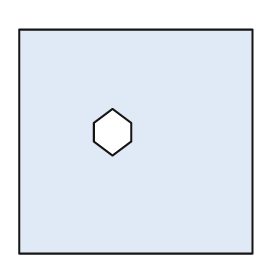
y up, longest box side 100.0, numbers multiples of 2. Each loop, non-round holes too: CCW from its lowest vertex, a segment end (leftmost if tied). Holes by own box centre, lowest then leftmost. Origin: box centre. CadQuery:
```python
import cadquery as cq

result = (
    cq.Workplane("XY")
    .moveTo(-50.0, -48.0)
    .lineTo(50.0, -48.0)
    .lineTo(50.0, 48.0)
    .lineTo(-50.0, 48.0)
    .close()
    .moveTo(-10.0, -6.0)
    .lineTo(-2.0, 0.0)
    .lineTo(-2.0, 8.0)
    .lineTo(-10.0, 14.0)
    .lineTo(-18.0, 8.0)
    .lineTo(-18.0, 0.0)
    .close()
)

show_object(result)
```